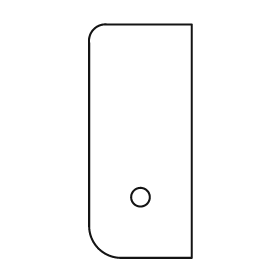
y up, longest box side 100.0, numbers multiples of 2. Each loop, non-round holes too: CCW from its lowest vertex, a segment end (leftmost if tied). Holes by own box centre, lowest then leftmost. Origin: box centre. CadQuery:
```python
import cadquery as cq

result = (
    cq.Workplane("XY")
    .moveTo(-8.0, -50.0)
    .lineTo(22.0, -50.0)
    .lineTo(22.0, 50.0)
    .lineTo(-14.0, 50.0)
    .threePointArc((-20.0, 48.0), (-22.0, 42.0))
    .lineTo(-22.0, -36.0)
    .threePointArc((-18.0, -46.0), (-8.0, -50.0))
    .close()
    .moveTo(0.0, -24.0)
    .circle(4.0)
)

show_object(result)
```